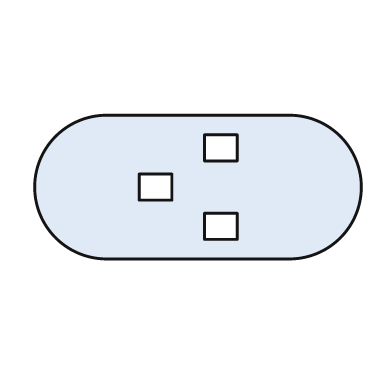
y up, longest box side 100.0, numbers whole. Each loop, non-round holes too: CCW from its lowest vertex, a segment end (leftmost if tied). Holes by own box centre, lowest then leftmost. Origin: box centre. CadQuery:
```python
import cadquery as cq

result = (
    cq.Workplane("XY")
    .moveTo(-28.0, -22.0)
    .lineTo(28.0, -22.0)
    .threePointArc((50.0, 0.0), (28.0, 22.0))
    .lineTo(-28.0, 22.0)
    .threePointArc((-50.0, 0.0), (-28.0, -22.0))
    .close()
    .moveTo(2.0, -16.0)
    .lineTo(12.0, -16.0)
    .lineTo(12.0, -8.0)
    .lineTo(2.0, -8.0)
    .close()
    .moveTo(-18.0, -4.0)
    .lineTo(-8.0, -4.0)
    .lineTo(-8.0, 4.0)
    .lineTo(-18.0, 4.0)
    .close()
    .moveTo(2.0, 8.0)
    .lineTo(12.0, 8.0)
    .lineTo(12.0, 16.0)
    .lineTo(2.0, 16.0)
    .close()
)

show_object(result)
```